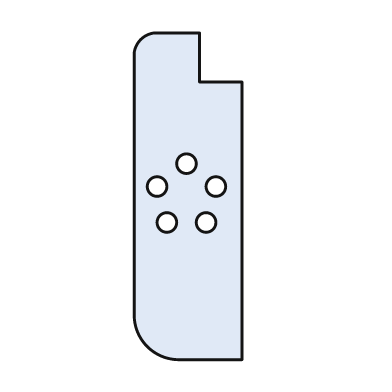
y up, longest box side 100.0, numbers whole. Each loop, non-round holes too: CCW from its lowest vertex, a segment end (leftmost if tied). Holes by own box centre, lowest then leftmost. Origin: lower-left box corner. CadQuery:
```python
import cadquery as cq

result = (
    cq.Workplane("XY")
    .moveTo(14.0, 0.0)
    .lineTo(33.0, 0.0)
    .lineTo(33.0, 85.0)
    .lineTo(20.0, 85.0)
    .lineTo(20.0, 100.0)
    .lineTo(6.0, 100.0)
    .threePointArc((2.0, 98.0), (0.0, 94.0))
    .lineTo(0.0, 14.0)
    .threePointArc((4.0, 4.0), (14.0, 0.0))
    .close()
    .moveTo(10.0, 42.0)
    .circle(3.0)
    .moveTo(22.0, 42.0)
    .circle(3.0)
    .moveTo(7.0, 53.0)
    .circle(3.0)
    .moveTo(25.0, 53.0)
    .circle(3.0)
    .moveTo(16.0, 60.0)
    .circle(3.0)
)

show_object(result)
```